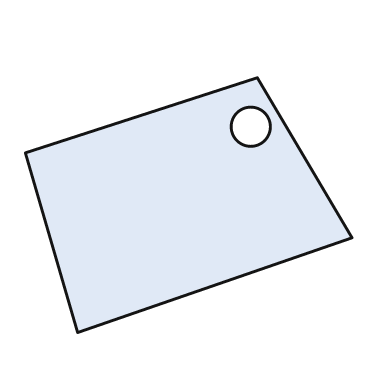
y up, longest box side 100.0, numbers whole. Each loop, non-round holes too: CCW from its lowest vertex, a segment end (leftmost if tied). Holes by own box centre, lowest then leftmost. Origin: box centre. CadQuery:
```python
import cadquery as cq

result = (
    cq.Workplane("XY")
    .moveTo(-34.0, -39.0)
    .lineTo(50.0, -10.0)
    .lineTo(21.0, 39.0)
    .lineTo(-50.0, 16.0)
    .close()
    .moveTo(19.0, 24.0)
    .circle(6.0)
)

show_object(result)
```